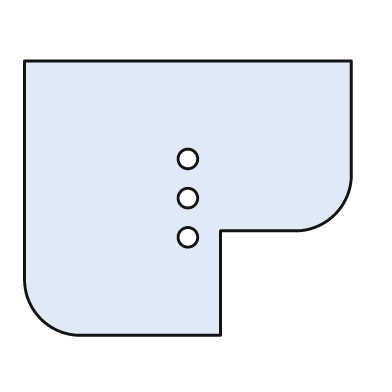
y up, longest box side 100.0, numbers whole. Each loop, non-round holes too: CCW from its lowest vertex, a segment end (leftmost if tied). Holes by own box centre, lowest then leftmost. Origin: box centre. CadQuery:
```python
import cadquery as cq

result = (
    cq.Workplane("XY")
    .moveTo(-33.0, -42.0)
    .lineTo(10.0, -42.0)
    .lineTo(10.0, -10.0)
    .lineTo(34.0, -10.0)
    .threePointArc((45.0, -5.0), (50.0, 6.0))
    .lineTo(50.0, 42.0)
    .lineTo(-50.0, 42.0)
    .lineTo(-50.0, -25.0)
    .threePointArc((-45.0, -37.0), (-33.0, -42.0))
    .close()
    .moveTo(0.0, -12.0)
    .circle(3.0)
    .moveTo(0.0, 0.0)
    .circle(3.0)
    .moveTo(0.0, 12.0)
    .circle(3.0)
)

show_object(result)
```